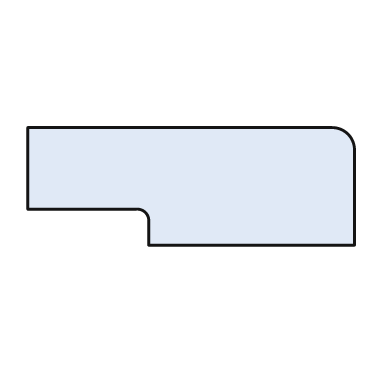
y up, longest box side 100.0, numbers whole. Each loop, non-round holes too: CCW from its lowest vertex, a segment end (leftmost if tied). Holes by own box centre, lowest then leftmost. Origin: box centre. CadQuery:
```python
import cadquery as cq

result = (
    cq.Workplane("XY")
    .moveTo(-13.0, -18.0)
    .lineTo(50.0, -18.0)
    .lineTo(50.0, 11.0)
    .threePointArc((48.0, 16.0), (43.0, 18.0))
    .lineTo(-50.0, 18.0)
    .lineTo(-50.0, -7.0)
    .lineTo(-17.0, -7.0)
    .threePointArc((-14.0, -8.0), (-13.0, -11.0))
    .close()
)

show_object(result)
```